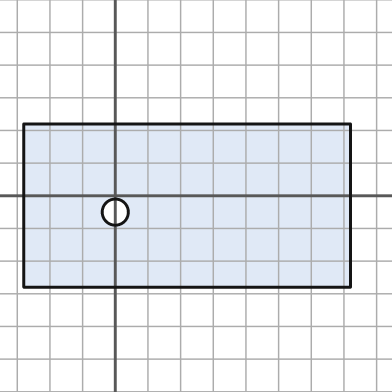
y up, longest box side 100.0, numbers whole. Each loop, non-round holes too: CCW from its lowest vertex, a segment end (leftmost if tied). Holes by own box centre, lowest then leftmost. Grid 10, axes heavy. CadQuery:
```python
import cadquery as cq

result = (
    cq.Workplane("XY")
    .moveTo(-28.0, -28.0)
    .lineTo(72.0, -28.0)
    .lineTo(72.0, 22.0)
    .lineTo(-28.0, 22.0)
    .close()
    .moveTo(0.0, -5.0)
    .circle(4.0)
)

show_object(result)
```